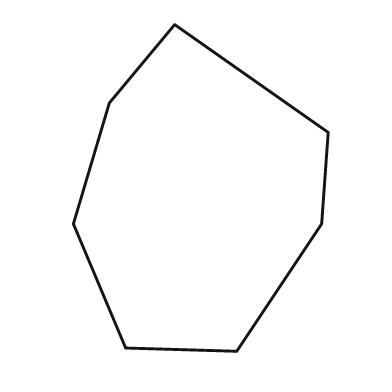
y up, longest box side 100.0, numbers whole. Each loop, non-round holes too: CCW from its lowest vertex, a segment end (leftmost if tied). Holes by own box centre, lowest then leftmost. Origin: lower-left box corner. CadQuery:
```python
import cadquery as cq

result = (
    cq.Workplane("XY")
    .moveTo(50.0, 0.0)
    .lineTo(76.0, 39.0)
    .lineTo(78.0, 67.0)
    .lineTo(31.0, 100.0)
    .lineTo(11.0, 76.0)
    .lineTo(0.0, 39.0)
    .lineTo(16.0, 1.0)
    .close()
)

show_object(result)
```